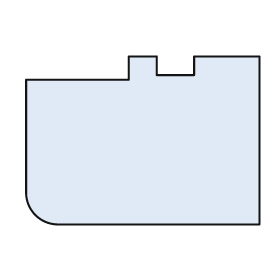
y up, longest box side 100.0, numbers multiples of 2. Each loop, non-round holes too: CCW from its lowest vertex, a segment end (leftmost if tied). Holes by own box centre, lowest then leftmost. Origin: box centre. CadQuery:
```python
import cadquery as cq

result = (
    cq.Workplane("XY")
    .moveTo(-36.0, -36.0)
    .lineTo(50.0, -36.0)
    .lineTo(50.0, 36.0)
    .lineTo(22.0, 36.0)
    .lineTo(22.0, 28.0)
    .lineTo(6.0, 28.0)
    .lineTo(6.0, 36.0)
    .lineTo(-6.0, 36.0)
    .lineTo(-6.0, 26.0)
    .lineTo(-50.0, 26.0)
    .lineTo(-50.0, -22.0)
    .threePointArc((-46.0, -32.0), (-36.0, -36.0))
    .close()
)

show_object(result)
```